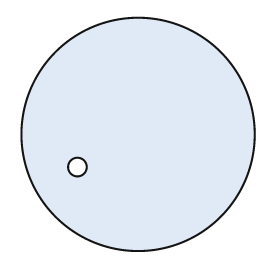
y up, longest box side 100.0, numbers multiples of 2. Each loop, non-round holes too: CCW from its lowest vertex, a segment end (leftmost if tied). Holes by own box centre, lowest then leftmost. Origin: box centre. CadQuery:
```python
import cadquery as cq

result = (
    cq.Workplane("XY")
    .moveTo(0.0, 0.0)
    .circle(50.0)
    .moveTo(-26.0, -14.0)
    .circle(4.0)
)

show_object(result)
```